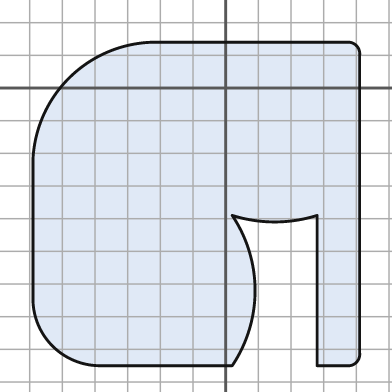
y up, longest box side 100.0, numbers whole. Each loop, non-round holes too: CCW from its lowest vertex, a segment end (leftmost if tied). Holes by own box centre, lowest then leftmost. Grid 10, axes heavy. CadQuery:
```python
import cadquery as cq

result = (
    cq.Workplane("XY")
    .moveTo(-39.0, -85.0)
    .lineTo(2.0, -85.0)
    .threePointArc((9.0, -62.0), (2.0, -39.0))
    .threePointArc((15.0, -41.0), (28.0, -39.0))
    .lineTo(28.0, -85.0)
    .lineTo(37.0, -85.0)
    .threePointArc((40.0, -84.0), (41.0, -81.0))
    .lineTo(41.0, 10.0)
    .threePointArc((40.0, 13.0), (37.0, 14.0))
    .lineTo(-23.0, 14.0)
    .threePointArc((-48.0, 3.0), (-59.0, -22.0))
    .lineTo(-59.0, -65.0)
    .threePointArc((-53.0, -79.0), (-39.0, -85.0))
    .close()
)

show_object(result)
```